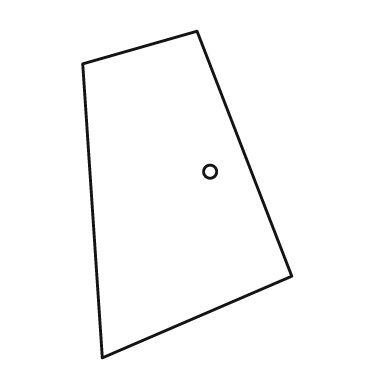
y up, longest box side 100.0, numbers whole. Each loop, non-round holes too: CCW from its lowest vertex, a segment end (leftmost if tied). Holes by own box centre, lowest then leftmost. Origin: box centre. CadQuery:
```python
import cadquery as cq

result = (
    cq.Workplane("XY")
    .moveTo(-26.0, -50.0)
    .lineTo(32.0, -25.0)
    .lineTo(3.0, 50.0)
    .lineTo(-32.0, 40.0)
    .close()
    .moveTo(7.0, 7.0)
    .circle(2.0)
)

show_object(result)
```